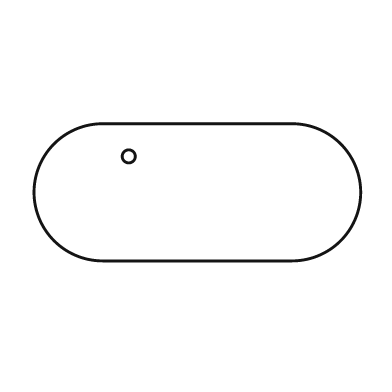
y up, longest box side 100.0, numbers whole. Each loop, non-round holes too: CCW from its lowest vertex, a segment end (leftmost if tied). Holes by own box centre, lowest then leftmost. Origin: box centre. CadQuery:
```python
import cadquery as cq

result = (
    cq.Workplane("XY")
    .moveTo(-29.0, -21.0)
    .lineTo(29.0, -21.0)
    .threePointArc((50.0, 0.0), (29.0, 21.0))
    .lineTo(-29.0, 21.0)
    .threePointArc((-50.0, 0.0), (-29.0, -21.0))
    .close()
    .moveTo(-21.0, 11.0)
    .circle(2.0)
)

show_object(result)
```